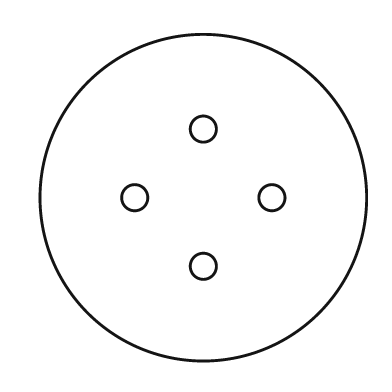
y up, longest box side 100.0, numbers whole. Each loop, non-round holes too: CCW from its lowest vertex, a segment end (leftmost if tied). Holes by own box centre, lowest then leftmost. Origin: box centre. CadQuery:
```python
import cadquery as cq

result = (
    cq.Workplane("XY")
    .moveTo(0.0, 0.0)
    .circle(50.0)
    .moveTo(0.0, -21.0)
    .circle(4.0)
    .moveTo(-21.0, 0.0)
    .circle(4.0)
    .moveTo(21.0, 0.0)
    .circle(4.0)
    .moveTo(0.0, 21.0)
    .circle(4.0)
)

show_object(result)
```